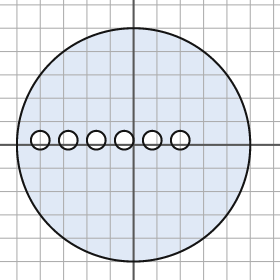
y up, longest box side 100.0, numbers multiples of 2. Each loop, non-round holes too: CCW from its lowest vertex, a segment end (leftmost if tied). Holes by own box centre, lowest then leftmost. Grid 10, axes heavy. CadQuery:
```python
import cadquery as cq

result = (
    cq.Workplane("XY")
    .moveTo(0.0, 0.0)
    .circle(50.0)
    .moveTo(-40.0, 2.0)
    .circle(4.0)
    .moveTo(-28.0, 2.0)
    .circle(4.0)
    .moveTo(-16.0, 2.0)
    .circle(4.0)
    .moveTo(-4.0, 2.0)
    .circle(4.0)
    .moveTo(8.0, 2.0)
    .circle(4.0)
    .moveTo(20.0, 2.0)
    .circle(4.0)
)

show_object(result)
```